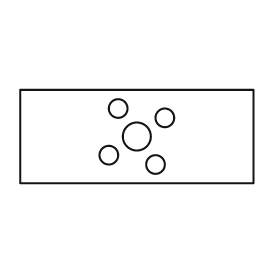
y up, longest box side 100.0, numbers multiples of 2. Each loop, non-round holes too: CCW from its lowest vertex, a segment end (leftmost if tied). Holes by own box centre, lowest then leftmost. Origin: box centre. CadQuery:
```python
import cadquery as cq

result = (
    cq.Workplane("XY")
    .moveTo(-50.0, -20.0)
    .lineTo(50.0, -20.0)
    .lineTo(50.0, 20.0)
    .lineTo(-50.0, 20.0)
    .close()
    .moveTo(8.0, -12.0)
    .circle(4.0)
    .moveTo(-12.0, -8.0)
    .circle(4.0)
    .moveTo(0.0, 0.0)
    .circle(6.0)
    .moveTo(12.0, 8.0)
    .circle(4.0)
    .moveTo(-8.0, 12.0)
    .circle(4.0)
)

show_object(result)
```